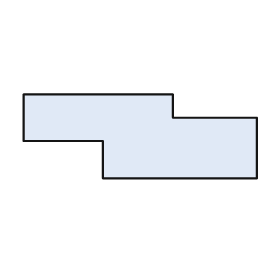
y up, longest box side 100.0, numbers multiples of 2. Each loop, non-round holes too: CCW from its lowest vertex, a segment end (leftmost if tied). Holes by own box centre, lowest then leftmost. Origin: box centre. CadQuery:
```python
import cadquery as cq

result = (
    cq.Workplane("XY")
    .moveTo(-16.0, -18.0)
    .lineTo(50.0, -18.0)
    .lineTo(50.0, 8.0)
    .lineTo(14.0, 8.0)
    .lineTo(14.0, 18.0)
    .lineTo(-50.0, 18.0)
    .lineTo(-50.0, -2.0)
    .lineTo(-16.0, -2.0)
    .close()
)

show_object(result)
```